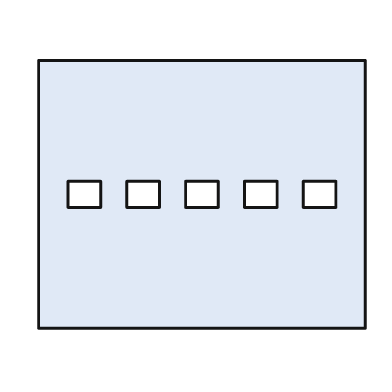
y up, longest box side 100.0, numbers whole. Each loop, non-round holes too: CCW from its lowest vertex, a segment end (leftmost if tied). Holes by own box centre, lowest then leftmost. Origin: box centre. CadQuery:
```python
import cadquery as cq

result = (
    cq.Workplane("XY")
    .moveTo(-50.0, -41.0)
    .lineTo(50.0, -41.0)
    .lineTo(50.0, 41.0)
    .lineTo(-50.0, 41.0)
    .close()
    .moveTo(-41.0, -4.0)
    .lineTo(-31.0, -4.0)
    .lineTo(-31.0, 4.0)
    .lineTo(-41.0, 4.0)
    .close()
    .moveTo(-23.0, -4.0)
    .lineTo(-13.0, -4.0)
    .lineTo(-13.0, 4.0)
    .lineTo(-23.0, 4.0)
    .close()
    .moveTo(-5.0, -4.0)
    .lineTo(5.0, -4.0)
    .lineTo(5.0, 4.0)
    .lineTo(-5.0, 4.0)
    .close()
    .moveTo(13.0, -4.0)
    .lineTo(23.0, -4.0)
    .lineTo(23.0, 4.0)
    .lineTo(13.0, 4.0)
    .close()
    .moveTo(31.0, -4.0)
    .lineTo(41.0, -4.0)
    .lineTo(41.0, 4.0)
    .lineTo(31.0, 4.0)
    .close()
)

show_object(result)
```